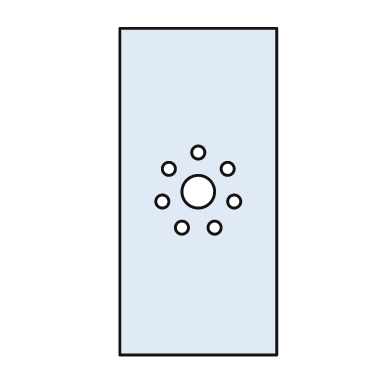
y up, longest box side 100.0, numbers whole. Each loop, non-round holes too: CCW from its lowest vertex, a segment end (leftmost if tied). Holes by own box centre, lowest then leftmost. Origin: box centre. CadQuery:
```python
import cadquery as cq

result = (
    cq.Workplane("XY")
    .moveTo(-24.0, -50.0)
    .lineTo(24.0, -50.0)
    .lineTo(24.0, 50.0)
    .lineTo(-24.0, 50.0)
    .close()
    .moveTo(-5.0, -11.0)
    .circle(2.0)
    .moveTo(5.0, -11.0)
    .circle(2.0)
    .moveTo(-11.0, -3.0)
    .circle(2.0)
    .moveTo(11.0, -3.0)
    .circle(2.0)
    .moveTo(0.0, 0.0)
    .circle(5.0)
    .moveTo(-9.0, 7.0)
    .circle(2.0)
    .moveTo(9.0, 7.0)
    .circle(2.0)
    .moveTo(0.0, 12.0)
    .circle(2.0)
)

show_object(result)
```